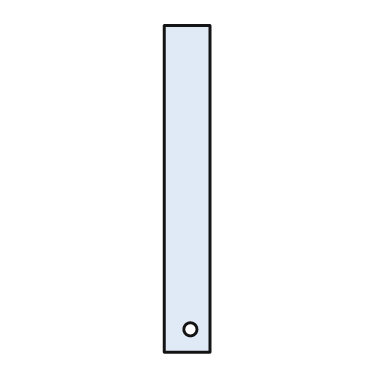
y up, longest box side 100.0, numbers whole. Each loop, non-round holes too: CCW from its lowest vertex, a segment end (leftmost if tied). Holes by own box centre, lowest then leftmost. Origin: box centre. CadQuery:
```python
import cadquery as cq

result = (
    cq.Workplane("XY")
    .moveTo(-7.0, -50.0)
    .lineTo(7.0, -50.0)
    .lineTo(7.0, 50.0)
    .lineTo(-7.0, 50.0)
    .close()
    .moveTo(1.0, -43.0)
    .circle(2.0)
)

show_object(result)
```